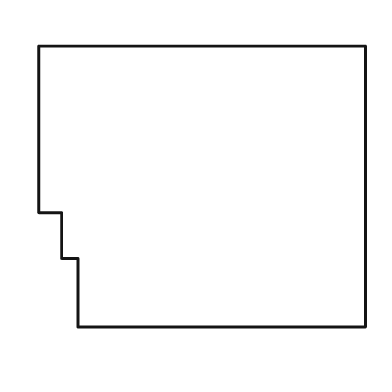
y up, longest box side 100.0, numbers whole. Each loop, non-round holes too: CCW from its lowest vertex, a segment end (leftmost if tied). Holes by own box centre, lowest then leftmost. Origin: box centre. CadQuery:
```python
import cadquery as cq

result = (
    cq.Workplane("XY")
    .moveTo(-38.0, -43.0)
    .lineTo(50.0, -43.0)
    .lineTo(50.0, 43.0)
    .lineTo(-50.0, 43.0)
    .lineTo(-50.0, -8.0)
    .lineTo(-43.0, -8.0)
    .lineTo(-43.0, -22.0)
    .lineTo(-38.0, -22.0)
    .close()
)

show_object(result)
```